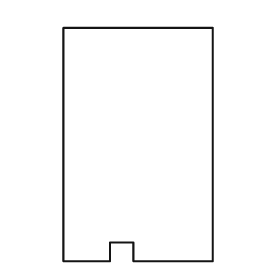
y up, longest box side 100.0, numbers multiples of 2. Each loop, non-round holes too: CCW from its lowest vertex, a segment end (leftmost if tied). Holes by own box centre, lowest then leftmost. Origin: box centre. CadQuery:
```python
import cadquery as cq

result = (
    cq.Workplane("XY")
    .moveTo(-32.0, -50.0)
    .lineTo(-12.0, -50.0)
    .lineTo(-12.0, -42.0)
    .lineTo(-2.0, -42.0)
    .lineTo(-2.0, -50.0)
    .lineTo(32.0, -50.0)
    .lineTo(32.0, 50.0)
    .lineTo(-32.0, 50.0)
    .close()
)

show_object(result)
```